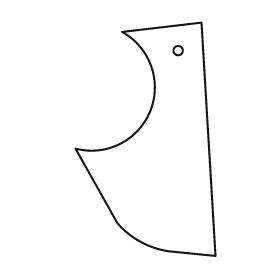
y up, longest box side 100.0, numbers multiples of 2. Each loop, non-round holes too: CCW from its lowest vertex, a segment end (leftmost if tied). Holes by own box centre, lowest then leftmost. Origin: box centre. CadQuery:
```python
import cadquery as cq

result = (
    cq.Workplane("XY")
    .moveTo(30.0, -50.0)
    .lineTo(24.0, 50.0)
    .lineTo(-10.0, 46.0)
    .threePointArc((2.0, 12.0), (-30.0, -4.0))
    .lineTo(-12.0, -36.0)
    .threePointArc((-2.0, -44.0), (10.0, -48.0))
    .close()
    .moveTo(14.0, 38.0)
    .circle(2.0)
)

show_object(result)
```